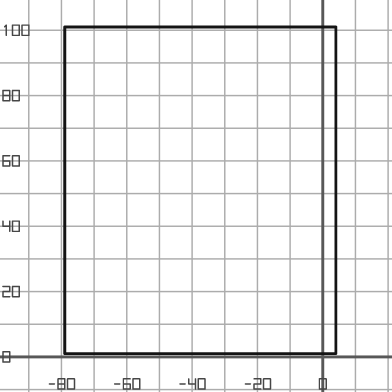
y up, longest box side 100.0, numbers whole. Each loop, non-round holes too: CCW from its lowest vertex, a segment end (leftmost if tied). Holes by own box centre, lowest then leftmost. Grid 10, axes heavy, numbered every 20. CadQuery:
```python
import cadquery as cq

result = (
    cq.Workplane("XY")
    .moveTo(-79.0, 1.0)
    .lineTo(4.0, 1.0)
    .lineTo(4.0, 101.0)
    .lineTo(-79.0, 101.0)
    .close()
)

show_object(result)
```